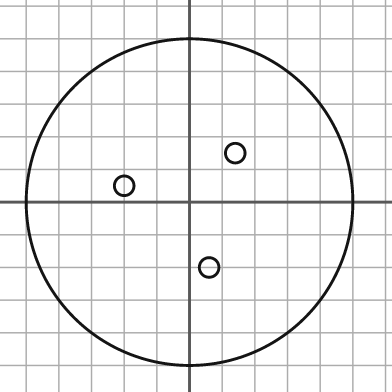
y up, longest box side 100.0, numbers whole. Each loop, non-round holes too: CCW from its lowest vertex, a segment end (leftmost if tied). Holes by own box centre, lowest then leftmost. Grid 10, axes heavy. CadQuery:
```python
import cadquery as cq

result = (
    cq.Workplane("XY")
    .moveTo(0.0, 0.0)
    .circle(50.0)
    .moveTo(6.0, -20.0)
    .circle(3.0)
    .moveTo(-20.0, 5.0)
    .circle(3.0)
    .moveTo(14.0, 15.0)
    .circle(3.0)
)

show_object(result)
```